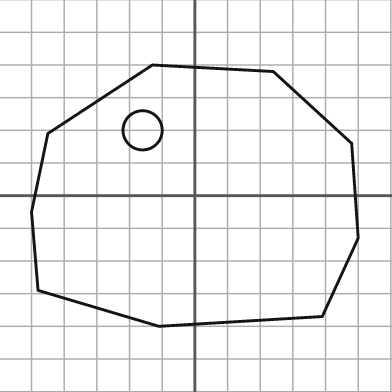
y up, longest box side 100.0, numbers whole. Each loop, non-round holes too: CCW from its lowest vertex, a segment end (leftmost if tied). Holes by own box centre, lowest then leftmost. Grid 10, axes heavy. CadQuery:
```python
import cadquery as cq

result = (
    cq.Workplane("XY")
    .moveTo(-11.0, -40.0)
    .lineTo(39.0, -37.0)
    .lineTo(50.0, -13.0)
    .lineTo(48.0, 16.0)
    .lineTo(24.0, 38.0)
    .lineTo(-13.0, 40.0)
    .lineTo(-45.0, 19.0)
    .lineTo(-50.0, -5.0)
    .lineTo(-48.0, -29.0)
    .close()
    .moveTo(-16.0, 20.0)
    .circle(6.0)
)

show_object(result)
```